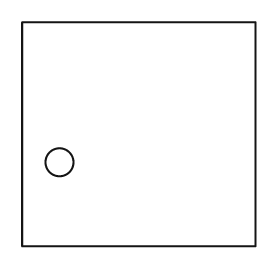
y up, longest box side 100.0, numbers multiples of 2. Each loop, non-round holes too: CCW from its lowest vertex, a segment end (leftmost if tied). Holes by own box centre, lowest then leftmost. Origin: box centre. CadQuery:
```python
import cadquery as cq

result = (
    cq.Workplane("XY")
    .moveTo(-50.0, -48.0)
    .lineTo(50.0, -48.0)
    .lineTo(50.0, 48.0)
    .lineTo(-50.0, 48.0)
    .close()
    .moveTo(-34.0, -12.0)
    .circle(6.0)
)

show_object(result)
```